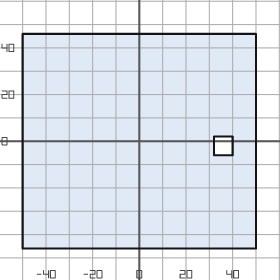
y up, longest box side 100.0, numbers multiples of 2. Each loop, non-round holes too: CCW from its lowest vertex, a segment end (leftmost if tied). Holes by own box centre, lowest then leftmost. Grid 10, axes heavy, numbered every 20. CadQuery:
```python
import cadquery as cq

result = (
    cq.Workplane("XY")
    .moveTo(-50.0, -46.0)
    .lineTo(50.0, -46.0)
    .lineTo(50.0, 46.0)
    .lineTo(-50.0, 46.0)
    .close()
    .moveTo(32.0, -6.0)
    .lineTo(40.0, -6.0)
    .lineTo(40.0, 2.0)
    .lineTo(32.0, 2.0)
    .close()
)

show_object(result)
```